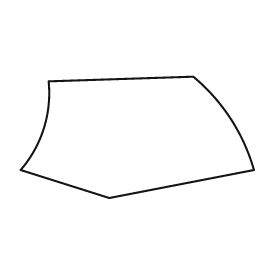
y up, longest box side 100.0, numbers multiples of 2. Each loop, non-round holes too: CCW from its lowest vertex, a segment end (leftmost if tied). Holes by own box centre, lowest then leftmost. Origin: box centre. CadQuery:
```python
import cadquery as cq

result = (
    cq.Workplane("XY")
    .moveTo(-12.0, -26.0)
    .lineTo(50.0, -14.0)
    .threePointArc((40.0, 8.0), (24.0, 26.0))
    .lineTo(-38.0, 24.0)
    .threePointArc((-40.0, 4.0), (-50.0, -14.0))
    .close()
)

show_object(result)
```